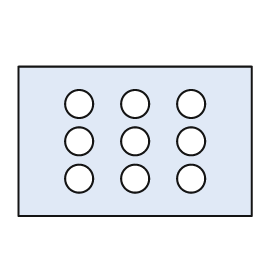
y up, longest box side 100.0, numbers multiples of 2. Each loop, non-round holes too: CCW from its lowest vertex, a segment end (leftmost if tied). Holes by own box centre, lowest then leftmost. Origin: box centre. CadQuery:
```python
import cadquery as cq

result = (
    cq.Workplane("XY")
    .moveTo(-50.0, -32.0)
    .lineTo(50.0, -32.0)
    .lineTo(50.0, 32.0)
    .lineTo(-50.0, 32.0)
    .close()
    .moveTo(-24.0, -16.0)
    .circle(6.0)
    .moveTo(0.0, -16.0)
    .circle(6.0)
    .moveTo(24.0, -16.0)
    .circle(6.0)
    .moveTo(-24.0, 0.0)
    .circle(6.0)
    .moveTo(0.0, 0.0)
    .circle(6.0)
    .moveTo(24.0, 0.0)
    .circle(6.0)
    .moveTo(-24.0, 16.0)
    .circle(6.0)
    .moveTo(0.0, 16.0)
    .circle(6.0)
    .moveTo(24.0, 16.0)
    .circle(6.0)
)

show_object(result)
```